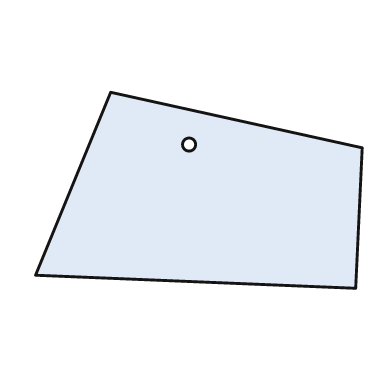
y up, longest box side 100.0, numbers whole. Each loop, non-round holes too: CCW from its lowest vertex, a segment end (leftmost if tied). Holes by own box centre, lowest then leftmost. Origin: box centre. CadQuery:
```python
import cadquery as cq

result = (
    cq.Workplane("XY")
    .moveTo(48.0, -30.0)
    .lineTo(50.0, 13.0)
    .lineTo(-27.0, 30.0)
    .lineTo(-50.0, -26.0)
    .close()
    .moveTo(-3.0, 14.0)
    .circle(2.0)
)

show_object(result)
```